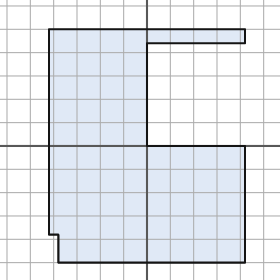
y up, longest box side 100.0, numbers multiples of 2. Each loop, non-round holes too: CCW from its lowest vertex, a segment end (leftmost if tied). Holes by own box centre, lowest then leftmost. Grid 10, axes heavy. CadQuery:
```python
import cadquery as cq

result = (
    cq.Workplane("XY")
    .moveTo(-38.0, -50.0)
    .lineTo(42.0, -50.0)
    .lineTo(42.0, 0.0)
    .lineTo(0.0, 0.0)
    .lineTo(0.0, 44.0)
    .lineTo(42.0, 44.0)
    .lineTo(42.0, 50.0)
    .lineTo(-42.0, 50.0)
    .lineTo(-42.0, -38.0)
    .lineTo(-38.0, -38.0)
    .close()
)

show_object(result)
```